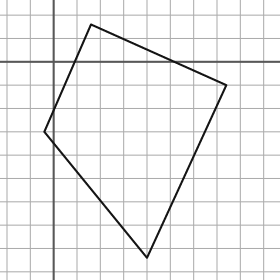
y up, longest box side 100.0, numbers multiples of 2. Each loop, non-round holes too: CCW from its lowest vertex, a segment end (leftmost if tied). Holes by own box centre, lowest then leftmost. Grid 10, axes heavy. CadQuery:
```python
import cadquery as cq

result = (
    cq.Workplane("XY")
    .moveTo(40.0, -84.0)
    .lineTo(74.0, -10.0)
    .lineTo(16.0, 16.0)
    .lineTo(-4.0, -30.0)
    .close()
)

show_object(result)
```